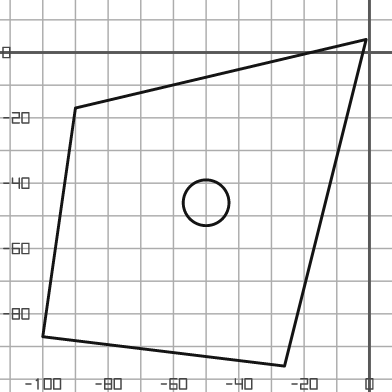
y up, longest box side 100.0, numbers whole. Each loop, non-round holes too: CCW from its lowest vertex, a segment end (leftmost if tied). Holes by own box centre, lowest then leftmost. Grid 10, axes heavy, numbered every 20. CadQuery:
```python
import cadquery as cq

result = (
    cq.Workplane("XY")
    .moveTo(-26.0, -96.0)
    .lineTo(-1.0, 4.0)
    .lineTo(-90.0, -17.0)
    .lineTo(-100.0, -87.0)
    .close()
    .moveTo(-50.0, -46.0)
    .circle(7.0)
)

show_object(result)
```